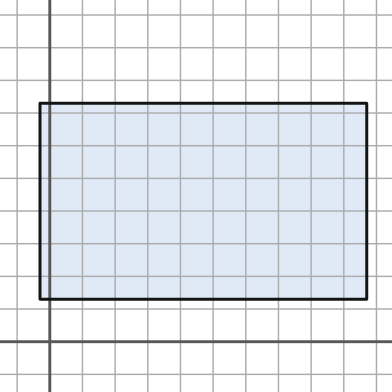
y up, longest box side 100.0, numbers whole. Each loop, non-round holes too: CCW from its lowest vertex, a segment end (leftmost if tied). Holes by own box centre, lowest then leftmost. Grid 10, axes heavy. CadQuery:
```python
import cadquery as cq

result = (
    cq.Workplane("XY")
    .moveTo(-3.0, 13.0)
    .lineTo(97.0, 13.0)
    .lineTo(97.0, 73.0)
    .lineTo(-3.0, 73.0)
    .close()
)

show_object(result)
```